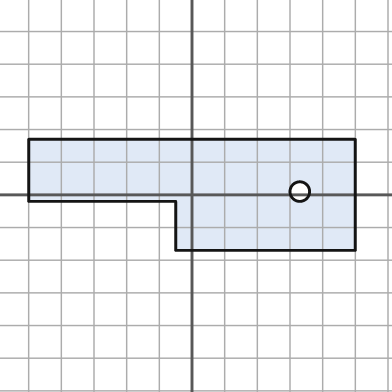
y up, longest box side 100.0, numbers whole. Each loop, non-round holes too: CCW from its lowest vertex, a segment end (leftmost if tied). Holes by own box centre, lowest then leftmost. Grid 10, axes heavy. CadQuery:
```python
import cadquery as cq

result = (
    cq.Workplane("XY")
    .moveTo(-5.0, -17.0)
    .lineTo(50.0, -17.0)
    .lineTo(50.0, 17.0)
    .lineTo(-50.0, 17.0)
    .lineTo(-50.0, -2.0)
    .lineTo(-5.0, -2.0)
    .close()
    .moveTo(33.0, 1.0)
    .circle(3.0)
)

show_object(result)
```